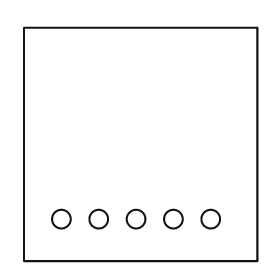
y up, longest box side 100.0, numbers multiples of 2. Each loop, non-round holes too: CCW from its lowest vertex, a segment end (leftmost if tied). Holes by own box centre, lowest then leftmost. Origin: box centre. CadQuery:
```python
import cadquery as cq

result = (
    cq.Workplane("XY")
    .moveTo(-50.0, -50.0)
    .lineTo(50.0, -50.0)
    .lineTo(50.0, 50.0)
    .lineTo(-50.0, 50.0)
    .close()
    .moveTo(-34.0, -32.0)
    .circle(4.0)
    .moveTo(-18.0, -32.0)
    .circle(4.0)
    .moveTo(-2.0, -32.0)
    .circle(4.0)
    .moveTo(14.0, -32.0)
    .circle(4.0)
    .moveTo(30.0, -32.0)
    .circle(4.0)
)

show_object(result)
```